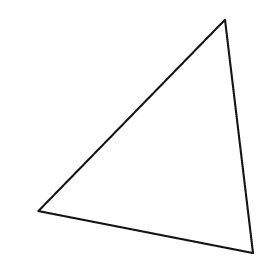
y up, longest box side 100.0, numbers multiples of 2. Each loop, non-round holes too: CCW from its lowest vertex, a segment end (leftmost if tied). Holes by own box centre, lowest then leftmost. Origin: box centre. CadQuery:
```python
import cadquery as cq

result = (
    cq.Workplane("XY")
    .moveTo(46.0, -50.0)
    .lineTo(34.0, 50.0)
    .lineTo(-46.0, -32.0)
    .close()
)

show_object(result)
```